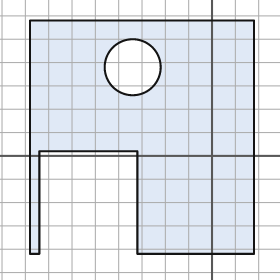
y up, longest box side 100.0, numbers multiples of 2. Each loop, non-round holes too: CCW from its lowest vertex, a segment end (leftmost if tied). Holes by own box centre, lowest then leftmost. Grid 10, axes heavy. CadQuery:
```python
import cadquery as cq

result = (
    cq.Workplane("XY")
    .moveTo(-78.0, -42.0)
    .lineTo(-74.0, -42.0)
    .lineTo(-74.0, 2.0)
    .lineTo(-32.0, 2.0)
    .lineTo(-32.0, -42.0)
    .lineTo(18.0, -42.0)
    .lineTo(18.0, 58.0)
    .lineTo(-78.0, 58.0)
    .close()
    .moveTo(-34.0, 38.0)
    .circle(12.0)
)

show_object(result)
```